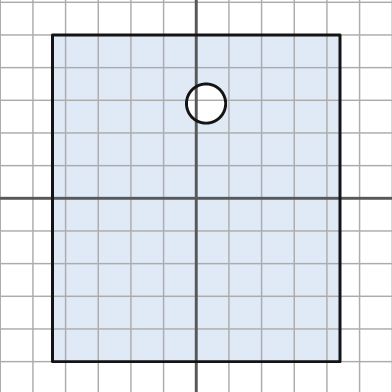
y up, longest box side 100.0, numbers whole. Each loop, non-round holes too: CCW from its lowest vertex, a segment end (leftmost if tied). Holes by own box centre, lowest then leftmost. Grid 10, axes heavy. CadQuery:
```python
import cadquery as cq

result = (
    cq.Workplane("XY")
    .moveTo(-44.0, -50.0)
    .lineTo(44.0, -50.0)
    .lineTo(44.0, 50.0)
    .lineTo(-44.0, 50.0)
    .close()
    .moveTo(3.0, 29.0)
    .circle(6.0)
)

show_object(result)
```